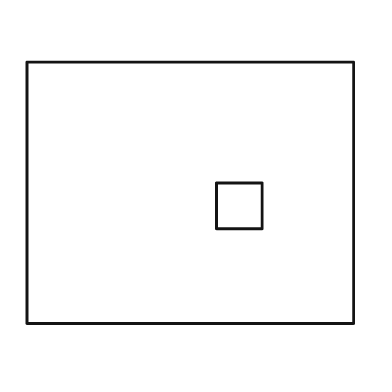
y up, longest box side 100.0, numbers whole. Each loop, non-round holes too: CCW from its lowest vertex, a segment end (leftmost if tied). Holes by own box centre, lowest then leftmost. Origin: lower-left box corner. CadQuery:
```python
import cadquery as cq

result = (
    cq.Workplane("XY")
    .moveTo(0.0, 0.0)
    .lineTo(100.0, 0.0)
    .lineTo(100.0, 80.0)
    .lineTo(0.0, 80.0)
    .close()
    .moveTo(58.0, 29.0)
    .lineTo(72.0, 29.0)
    .lineTo(72.0, 43.0)
    .lineTo(58.0, 43.0)
    .close()
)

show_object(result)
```